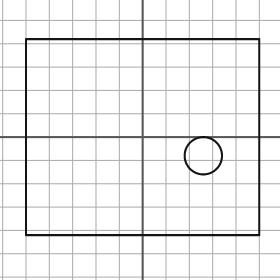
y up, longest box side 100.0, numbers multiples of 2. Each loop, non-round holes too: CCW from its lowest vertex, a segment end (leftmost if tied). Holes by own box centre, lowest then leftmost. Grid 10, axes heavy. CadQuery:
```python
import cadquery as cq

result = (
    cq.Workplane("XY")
    .moveTo(-50.0, -42.0)
    .lineTo(50.0, -42.0)
    .lineTo(50.0, 42.0)
    .lineTo(-50.0, 42.0)
    .close()
    .moveTo(26.0, -8.0)
    .circle(8.0)
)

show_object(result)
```